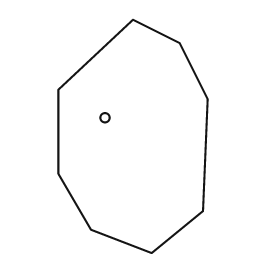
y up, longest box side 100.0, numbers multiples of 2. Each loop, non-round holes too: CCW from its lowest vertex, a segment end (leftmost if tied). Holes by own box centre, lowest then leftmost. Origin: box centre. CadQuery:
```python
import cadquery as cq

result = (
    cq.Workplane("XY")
    .moveTo(8.0, -50.0)
    .lineTo(30.0, -32.0)
    .lineTo(32.0, 16.0)
    .lineTo(20.0, 40.0)
    .lineTo(0.0, 50.0)
    .lineTo(-32.0, 20.0)
    .lineTo(-32.0, -16.0)
    .lineTo(-18.0, -40.0)
    .close()
    .moveTo(-12.0, 8.0)
    .circle(2.0)
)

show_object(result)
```